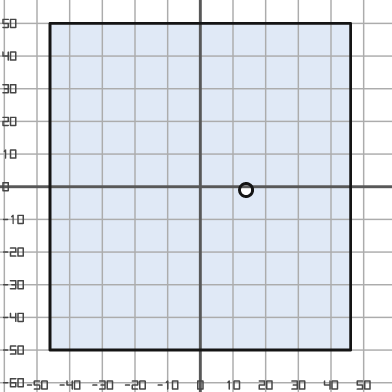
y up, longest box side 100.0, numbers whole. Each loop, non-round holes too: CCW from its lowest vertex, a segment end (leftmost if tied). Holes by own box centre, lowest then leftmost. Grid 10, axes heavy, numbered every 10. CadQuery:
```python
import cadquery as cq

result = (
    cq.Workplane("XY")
    .moveTo(-46.0, -50.0)
    .lineTo(46.0, -50.0)
    .lineTo(46.0, 50.0)
    .lineTo(-46.0, 50.0)
    .close()
    .moveTo(14.0, -1.0)
    .circle(2.0)
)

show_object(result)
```